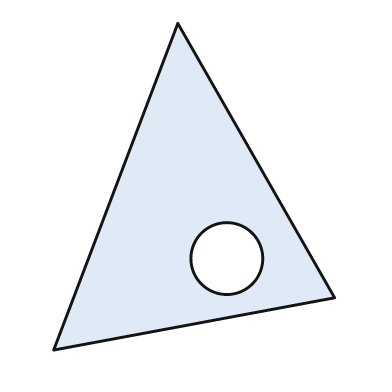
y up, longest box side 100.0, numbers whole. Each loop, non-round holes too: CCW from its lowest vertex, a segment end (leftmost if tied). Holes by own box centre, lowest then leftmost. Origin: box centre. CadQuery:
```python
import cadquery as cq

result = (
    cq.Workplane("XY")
    .moveTo(-43.0, -50.0)
    .lineTo(43.0, -34.0)
    .lineTo(-5.0, 50.0)
    .close()
    .moveTo(10.0, -22.0)
    .circle(11.0)
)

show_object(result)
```